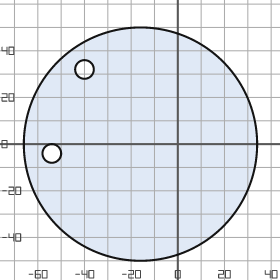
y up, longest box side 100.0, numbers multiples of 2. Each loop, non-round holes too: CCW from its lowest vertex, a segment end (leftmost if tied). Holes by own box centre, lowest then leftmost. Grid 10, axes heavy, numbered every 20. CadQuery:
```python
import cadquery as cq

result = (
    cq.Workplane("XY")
    .moveTo(-16.0, 0.0)
    .circle(50.0)
    .moveTo(-54.0, -4.0)
    .circle(4.0)
    .moveTo(-40.0, 32.0)
    .circle(4.0)
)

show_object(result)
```